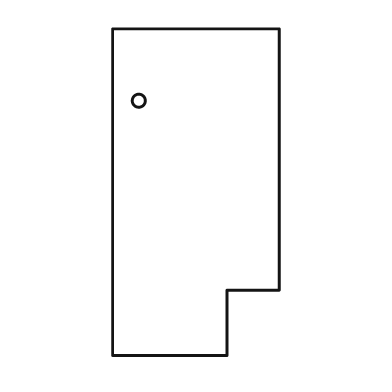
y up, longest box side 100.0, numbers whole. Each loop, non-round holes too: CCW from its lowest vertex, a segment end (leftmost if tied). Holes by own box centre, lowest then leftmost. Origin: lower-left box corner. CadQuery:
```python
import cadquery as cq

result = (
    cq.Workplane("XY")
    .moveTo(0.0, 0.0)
    .lineTo(35.0, 0.0)
    .lineTo(35.0, 20.0)
    .lineTo(51.0, 20.0)
    .lineTo(51.0, 100.0)
    .lineTo(0.0, 100.0)
    .close()
    .moveTo(8.0, 78.0)
    .circle(2.0)
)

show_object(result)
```